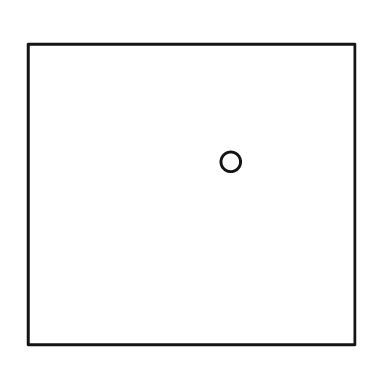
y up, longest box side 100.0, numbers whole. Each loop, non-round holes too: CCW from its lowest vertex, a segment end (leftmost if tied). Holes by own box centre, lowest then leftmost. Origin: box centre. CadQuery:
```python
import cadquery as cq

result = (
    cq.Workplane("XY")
    .moveTo(-50.0, -46.0)
    .lineTo(50.0, -46.0)
    .lineTo(50.0, 46.0)
    .lineTo(-50.0, 46.0)
    .close()
    .moveTo(12.0, 10.0)
    .circle(3.0)
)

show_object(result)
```